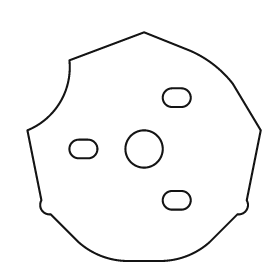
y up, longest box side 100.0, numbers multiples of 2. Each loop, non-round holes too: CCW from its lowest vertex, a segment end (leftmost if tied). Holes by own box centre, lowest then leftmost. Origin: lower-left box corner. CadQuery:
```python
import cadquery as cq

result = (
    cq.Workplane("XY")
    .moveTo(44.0, 0.0)
    .lineTo(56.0, 0.0)
    .threePointArc((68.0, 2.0), (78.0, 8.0))
    .lineTo(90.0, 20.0)
    .threePointArc((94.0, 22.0), (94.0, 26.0))
    .lineTo(100.0, 56.0)
    .lineTo(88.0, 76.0)
    .threePointArc((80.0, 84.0), (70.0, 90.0))
    .lineTo(50.0, 98.0)
    .lineTo(18.0, 86.0)
    .threePointArc((14.0, 68.0), (0.0, 56.0))
    .lineTo(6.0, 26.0)
    .threePointArc((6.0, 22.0), (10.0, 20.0))
    .lineTo(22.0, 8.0)
    .threePointArc((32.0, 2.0), (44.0, 0.0))
    .close()
    .moveTo(62.0, 22.0)
    .lineTo(66.0, 22.0)
    .threePointArc((70.0, 26.0), (66.0, 30.0))
    .lineTo(62.0, 30.0)
    .threePointArc((58.0, 26.0), (62.0, 22.0))
    .close()
    .moveTo(22.0, 44.0)
    .lineTo(26.0, 44.0)
    .threePointArc((30.0, 48.0), (26.0, 52.0))
    .lineTo(22.0, 52.0)
    .threePointArc((18.0, 48.0), (22.0, 44.0))
    .close()
    .moveTo(50.0, 48.0)
    .circle(8.0)
    .moveTo(62.0, 66.0)
    .lineTo(66.0, 66.0)
    .threePointArc((70.0, 70.0), (66.0, 74.0))
    .lineTo(62.0, 74.0)
    .threePointArc((58.0, 70.0), (62.0, 66.0))
    .close()
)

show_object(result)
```